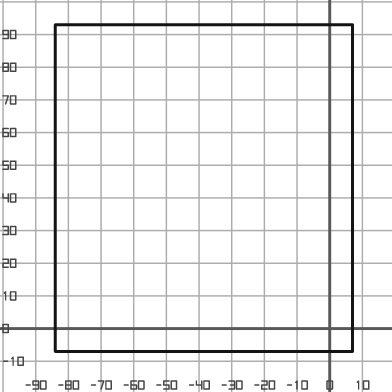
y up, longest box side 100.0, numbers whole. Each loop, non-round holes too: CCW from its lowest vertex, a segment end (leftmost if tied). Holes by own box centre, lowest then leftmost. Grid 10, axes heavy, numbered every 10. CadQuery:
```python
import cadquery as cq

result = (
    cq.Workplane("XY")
    .moveTo(-84.0, -7.0)
    .lineTo(7.0, -7.0)
    .lineTo(7.0, 93.0)
    .lineTo(-84.0, 93.0)
    .close()
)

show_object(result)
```